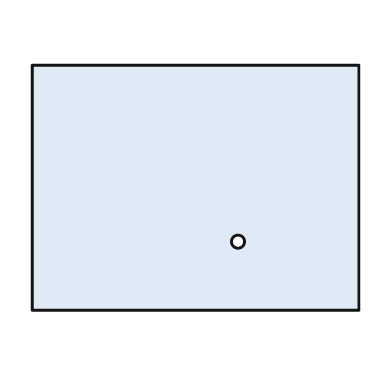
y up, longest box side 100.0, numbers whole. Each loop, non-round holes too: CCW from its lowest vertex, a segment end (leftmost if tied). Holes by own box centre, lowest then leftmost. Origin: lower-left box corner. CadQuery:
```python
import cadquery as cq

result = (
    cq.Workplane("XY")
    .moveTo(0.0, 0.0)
    .lineTo(100.0, 0.0)
    .lineTo(100.0, 75.0)
    .lineTo(0.0, 75.0)
    .close()
    .moveTo(63.0, 21.0)
    .circle(2.0)
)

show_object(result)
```